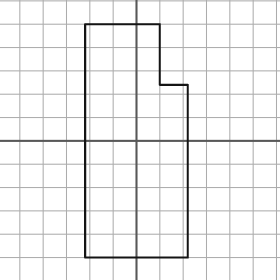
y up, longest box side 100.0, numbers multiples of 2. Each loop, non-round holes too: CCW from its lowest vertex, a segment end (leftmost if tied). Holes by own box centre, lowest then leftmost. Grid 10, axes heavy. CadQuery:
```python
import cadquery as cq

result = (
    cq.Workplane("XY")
    .moveTo(-22.0, -50.0)
    .lineTo(22.0, -50.0)
    .lineTo(22.0, 24.0)
    .lineTo(10.0, 24.0)
    .lineTo(10.0, 50.0)
    .lineTo(-22.0, 50.0)
    .close()
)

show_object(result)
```